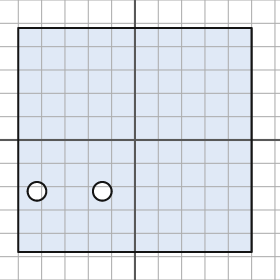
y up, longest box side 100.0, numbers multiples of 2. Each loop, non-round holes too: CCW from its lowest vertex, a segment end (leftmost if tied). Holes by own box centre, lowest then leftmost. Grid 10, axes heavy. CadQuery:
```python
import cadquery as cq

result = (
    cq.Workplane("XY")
    .moveTo(-50.0, -48.0)
    .lineTo(50.0, -48.0)
    .lineTo(50.0, 48.0)
    .lineTo(-50.0, 48.0)
    .close()
    .moveTo(-42.0, -22.0)
    .circle(4.0)
    .moveTo(-14.0, -22.0)
    .circle(4.0)
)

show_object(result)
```